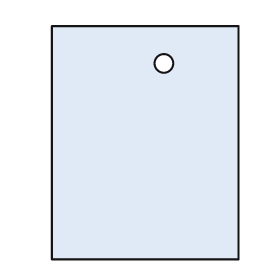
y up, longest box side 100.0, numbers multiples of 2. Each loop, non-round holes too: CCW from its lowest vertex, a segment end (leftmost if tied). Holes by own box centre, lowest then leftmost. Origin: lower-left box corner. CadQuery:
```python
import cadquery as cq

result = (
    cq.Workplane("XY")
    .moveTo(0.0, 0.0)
    .lineTo(80.0, 0.0)
    .lineTo(80.0, 100.0)
    .lineTo(0.0, 100.0)
    .close()
    .moveTo(48.0, 84.0)
    .circle(4.0)
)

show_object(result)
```